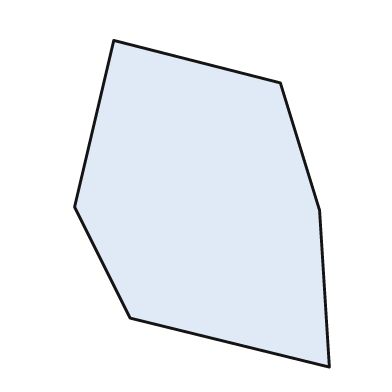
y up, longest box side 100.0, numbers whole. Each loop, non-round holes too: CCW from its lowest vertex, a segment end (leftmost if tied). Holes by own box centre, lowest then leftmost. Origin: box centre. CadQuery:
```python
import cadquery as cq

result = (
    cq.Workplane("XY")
    .moveTo(39.0, -50.0)
    .lineTo(36.0, -2.0)
    .lineTo(24.0, 37.0)
    .lineTo(-27.0, 50.0)
    .lineTo(-39.0, -1.0)
    .lineTo(-22.0, -35.0)
    .close()
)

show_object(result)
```